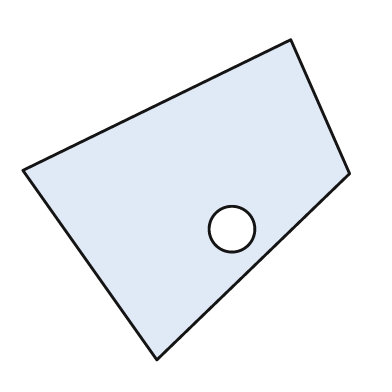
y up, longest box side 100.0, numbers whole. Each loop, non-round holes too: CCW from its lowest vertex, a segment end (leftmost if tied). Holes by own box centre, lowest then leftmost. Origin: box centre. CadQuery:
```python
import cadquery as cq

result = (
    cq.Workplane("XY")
    .moveTo(-9.0, -49.0)
    .lineTo(50.0, 8.0)
    .lineTo(32.0, 49.0)
    .lineTo(-50.0, 9.0)
    .close()
    .moveTo(14.0, -9.0)
    .circle(7.0)
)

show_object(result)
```